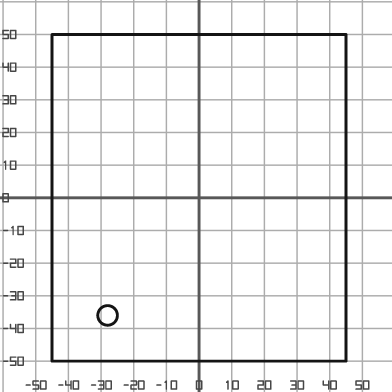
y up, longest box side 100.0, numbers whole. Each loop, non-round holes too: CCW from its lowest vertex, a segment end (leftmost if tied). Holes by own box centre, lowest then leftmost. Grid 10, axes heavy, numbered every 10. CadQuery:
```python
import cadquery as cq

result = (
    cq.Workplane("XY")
    .moveTo(-45.0, -50.0)
    .lineTo(45.0, -50.0)
    .lineTo(45.0, 50.0)
    .lineTo(-45.0, 50.0)
    .close()
    .moveTo(-28.0, -36.0)
    .circle(3.0)
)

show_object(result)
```